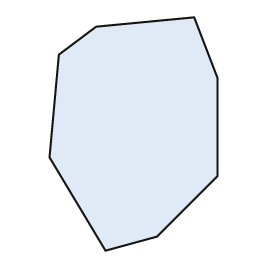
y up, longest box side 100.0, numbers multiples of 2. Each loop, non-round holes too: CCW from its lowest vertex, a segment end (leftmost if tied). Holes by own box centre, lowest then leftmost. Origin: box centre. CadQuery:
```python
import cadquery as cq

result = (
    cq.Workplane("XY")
    .moveTo(-12.0, -50.0)
    .lineTo(10.0, -44.0)
    .lineTo(36.0, -18.0)
    .lineTo(36.0, 24.0)
    .lineTo(26.0, 50.0)
    .lineTo(-16.0, 46.0)
    .lineTo(-32.0, 34.0)
    .lineTo(-36.0, -10.0)
    .close()
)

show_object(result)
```